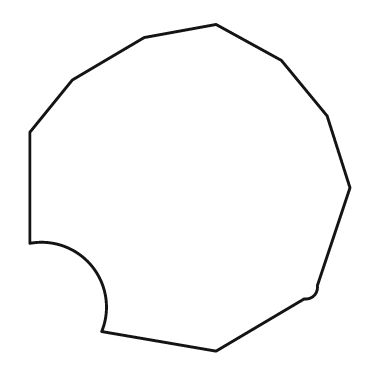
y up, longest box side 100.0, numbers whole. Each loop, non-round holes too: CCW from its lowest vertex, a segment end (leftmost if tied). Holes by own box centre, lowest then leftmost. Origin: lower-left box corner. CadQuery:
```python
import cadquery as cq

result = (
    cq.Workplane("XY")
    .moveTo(57.0, 0.0)
    .lineTo(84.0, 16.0)
    .threePointArc((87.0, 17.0), (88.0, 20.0))
    .lineTo(98.0, 50.0)
    .lineTo(91.0, 72.0)
    .lineTo(77.0, 89.0)
    .lineTo(57.0, 100.0)
    .lineTo(35.0, 96.0)
    .lineTo(13.0, 83.0)
    .lineTo(0.0, 67.0)
    .lineTo(0.0, 33.0)
    .threePointArc((19.0, 26.0), (22.0, 6.0))
    .close()
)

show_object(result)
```